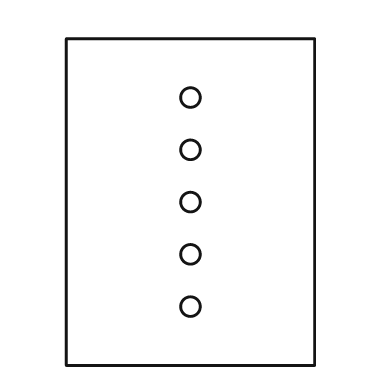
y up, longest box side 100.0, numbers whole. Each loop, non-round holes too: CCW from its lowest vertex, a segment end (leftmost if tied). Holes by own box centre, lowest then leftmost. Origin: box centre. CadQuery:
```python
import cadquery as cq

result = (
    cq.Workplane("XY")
    .moveTo(-38.0, -50.0)
    .lineTo(38.0, -50.0)
    .lineTo(38.0, 50.0)
    .lineTo(-38.0, 50.0)
    .close()
    .moveTo(0.0, -32.0)
    .circle(3.0)
    .moveTo(0.0, -16.0)
    .circle(3.0)
    .moveTo(0.0, 0.0)
    .circle(3.0)
    .moveTo(0.0, 16.0)
    .circle(3.0)
    .moveTo(0.0, 32.0)
    .circle(3.0)
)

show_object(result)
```